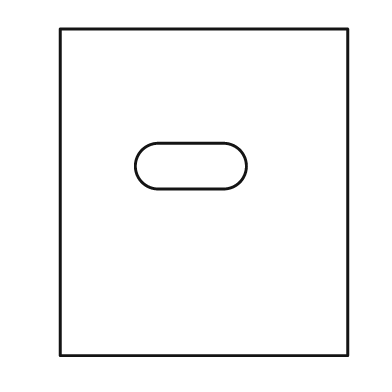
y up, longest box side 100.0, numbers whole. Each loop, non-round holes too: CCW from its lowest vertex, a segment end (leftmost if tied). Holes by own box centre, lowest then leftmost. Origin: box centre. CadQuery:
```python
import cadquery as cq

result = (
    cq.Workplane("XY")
    .moveTo(-44.0, -50.0)
    .lineTo(44.0, -50.0)
    .lineTo(44.0, 50.0)
    .lineTo(-44.0, 50.0)
    .close()
    .moveTo(-14.0, 1.0)
    .lineTo(6.0, 1.0)
    .threePointArc((13.0, 8.0), (6.0, 15.0))
    .lineTo(-14.0, 15.0)
    .threePointArc((-21.0, 8.0), (-14.0, 1.0))
    .close()
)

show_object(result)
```